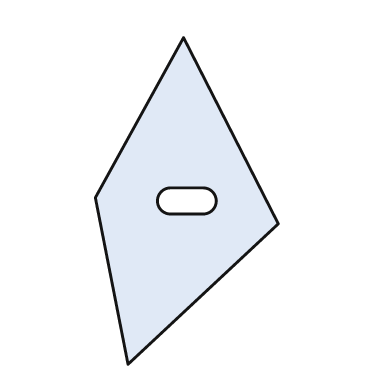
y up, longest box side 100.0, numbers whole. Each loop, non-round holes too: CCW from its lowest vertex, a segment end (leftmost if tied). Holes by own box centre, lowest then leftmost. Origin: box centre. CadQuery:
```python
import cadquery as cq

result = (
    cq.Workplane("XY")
    .moveTo(-18.0, -50.0)
    .lineTo(28.0, -7.0)
    .lineTo(-1.0, 50.0)
    .lineTo(-28.0, 1.0)
    .close()
    .moveTo(-5.0, -4.0)
    .lineTo(5.0, -4.0)
    .threePointArc((9.0, 0.0), (5.0, 4.0))
    .lineTo(-5.0, 4.0)
    .threePointArc((-9.0, 0.0), (-5.0, -4.0))
    .close()
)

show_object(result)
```